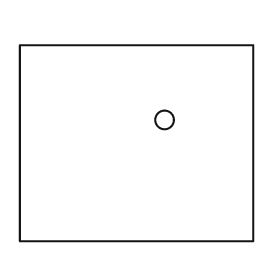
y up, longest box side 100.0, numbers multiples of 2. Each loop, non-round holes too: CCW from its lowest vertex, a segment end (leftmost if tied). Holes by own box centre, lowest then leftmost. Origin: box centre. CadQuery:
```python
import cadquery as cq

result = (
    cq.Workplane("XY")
    .moveTo(-50.0, -42.0)
    .lineTo(50.0, -42.0)
    .lineTo(50.0, 42.0)
    .lineTo(-50.0, 42.0)
    .close()
    .moveTo(12.0, 10.0)
    .circle(4.0)
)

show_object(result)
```